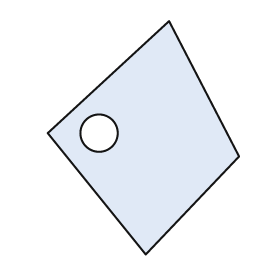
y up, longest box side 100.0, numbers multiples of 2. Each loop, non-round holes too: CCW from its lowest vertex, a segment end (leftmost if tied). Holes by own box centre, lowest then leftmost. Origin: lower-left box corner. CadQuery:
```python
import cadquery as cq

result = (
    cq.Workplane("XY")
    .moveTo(42.0, 0.0)
    .lineTo(82.0, 42.0)
    .lineTo(52.0, 100.0)
    .lineTo(0.0, 52.0)
    .close()
    .moveTo(22.0, 52.0)
    .circle(8.0)
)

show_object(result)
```